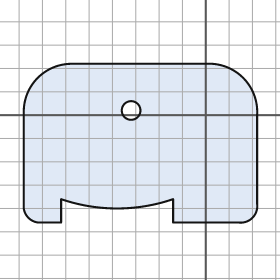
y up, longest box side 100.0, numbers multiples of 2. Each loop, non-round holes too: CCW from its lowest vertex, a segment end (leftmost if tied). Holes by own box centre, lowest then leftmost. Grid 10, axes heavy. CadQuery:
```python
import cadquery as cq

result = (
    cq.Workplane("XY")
    .moveTo(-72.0, -46.0)
    .lineTo(-62.0, -46.0)
    .lineTo(-62.0, -36.0)
    .threePointArc((-38.0, -40.0), (-14.0, -36.0))
    .lineTo(-14.0, -46.0)
    .lineTo(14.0, -46.0)
    .threePointArc((20.0, -44.0), (22.0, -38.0))
    .lineTo(22.0, 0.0)
    .threePointArc((16.0, 16.0), (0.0, 22.0))
    .lineTo(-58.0, 22.0)
    .threePointArc((-72.0, 16.0), (-78.0, 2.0))
    .lineTo(-78.0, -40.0)
    .threePointArc((-76.0, -44.0), (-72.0, -46.0))
    .close()
    .moveTo(-32.0, 2.0)
    .circle(4.0)
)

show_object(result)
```